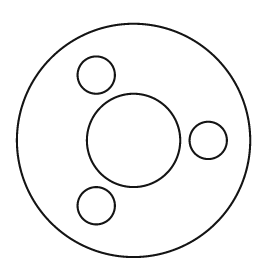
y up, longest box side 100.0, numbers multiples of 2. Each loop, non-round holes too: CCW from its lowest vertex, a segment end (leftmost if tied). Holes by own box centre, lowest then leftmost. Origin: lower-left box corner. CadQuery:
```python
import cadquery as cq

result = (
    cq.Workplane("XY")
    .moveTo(50.0, 50.0)
    .circle(50.0)
    .moveTo(34.0, 22.0)
    .circle(8.0)
    .moveTo(50.0, 50.0)
    .circle(20.0)
    .moveTo(82.0, 50.0)
    .circle(8.0)
    .moveTo(34.0, 78.0)
    .circle(8.0)
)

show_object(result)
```